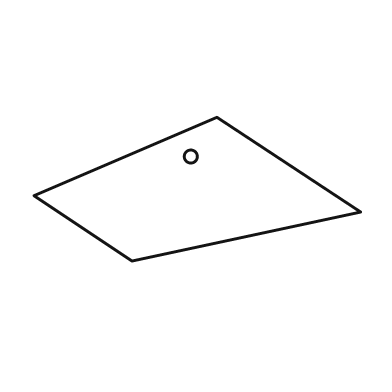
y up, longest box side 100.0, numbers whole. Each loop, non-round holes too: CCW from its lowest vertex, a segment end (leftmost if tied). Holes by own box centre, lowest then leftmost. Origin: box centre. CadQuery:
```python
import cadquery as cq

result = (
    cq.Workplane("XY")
    .moveTo(-20.0, -22.0)
    .lineTo(50.0, -7.0)
    .lineTo(6.0, 22.0)
    .lineTo(-50.0, -2.0)
    .close()
    .moveTo(-2.0, 10.0)
    .circle(2.0)
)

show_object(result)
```